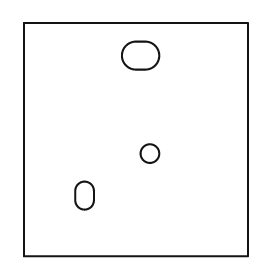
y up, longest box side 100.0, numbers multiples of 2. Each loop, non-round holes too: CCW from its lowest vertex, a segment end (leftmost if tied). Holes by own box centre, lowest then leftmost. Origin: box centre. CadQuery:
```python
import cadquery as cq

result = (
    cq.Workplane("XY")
    .moveTo(-48.0, -50.0)
    .lineTo(48.0, -50.0)
    .lineTo(48.0, 50.0)
    .lineTo(-48.0, 50.0)
    .close()
    .moveTo(-26.0, -26.0)
    .threePointArc((-22.0, -30.0), (-18.0, -26.0))
    .lineTo(-18.0, -22.0)
    .threePointArc((-22.0, -18.0), (-26.0, -22.0))
    .close()
    .moveTo(6.0, -6.0)
    .circle(4.0)
    .moveTo(0.0, 30.0)
    .lineTo(4.0, 30.0)
    .threePointArc((10.0, 36.0), (4.0, 42.0))
    .lineTo(0.0, 42.0)
    .threePointArc((-6.0, 36.0), (0.0, 30.0))
    .close()
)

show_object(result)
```